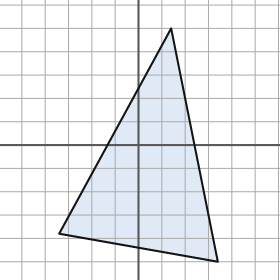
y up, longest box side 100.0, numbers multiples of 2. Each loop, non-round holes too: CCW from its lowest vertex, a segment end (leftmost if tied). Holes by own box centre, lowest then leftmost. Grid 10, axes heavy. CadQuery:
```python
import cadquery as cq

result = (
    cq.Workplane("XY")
    .moveTo(34.0, -50.0)
    .lineTo(14.0, 50.0)
    .lineTo(-34.0, -38.0)
    .close()
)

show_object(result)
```